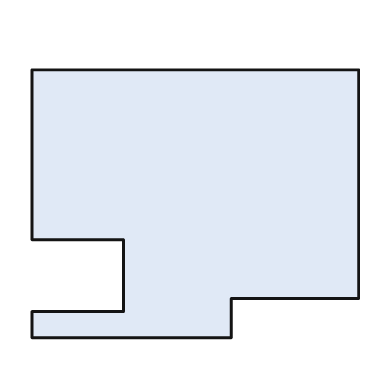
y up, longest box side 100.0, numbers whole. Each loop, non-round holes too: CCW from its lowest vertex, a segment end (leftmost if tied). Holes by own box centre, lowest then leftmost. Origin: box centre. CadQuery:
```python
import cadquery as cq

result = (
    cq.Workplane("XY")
    .moveTo(-50.0, -41.0)
    .lineTo(11.0, -41.0)
    .lineTo(11.0, -29.0)
    .lineTo(50.0, -29.0)
    .lineTo(50.0, 41.0)
    .lineTo(-50.0, 41.0)
    .lineTo(-50.0, -11.0)
    .lineTo(-22.0, -11.0)
    .lineTo(-22.0, -33.0)
    .lineTo(-50.0, -33.0)
    .close()
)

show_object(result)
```